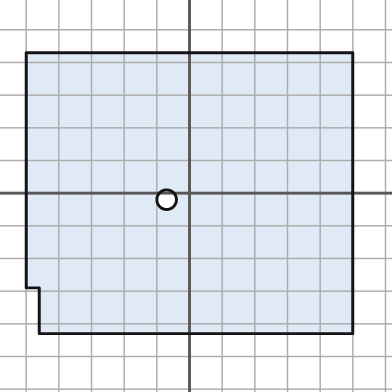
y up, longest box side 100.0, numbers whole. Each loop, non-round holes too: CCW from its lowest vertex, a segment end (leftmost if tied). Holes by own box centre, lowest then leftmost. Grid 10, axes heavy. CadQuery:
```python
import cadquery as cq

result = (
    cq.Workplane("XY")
    .moveTo(-46.0, -43.0)
    .lineTo(50.0, -43.0)
    .lineTo(50.0, 43.0)
    .lineTo(-50.0, 43.0)
    .lineTo(-50.0, -29.0)
    .lineTo(-46.0, -29.0)
    .close()
    .moveTo(-7.0, -2.0)
    .circle(3.0)
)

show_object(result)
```